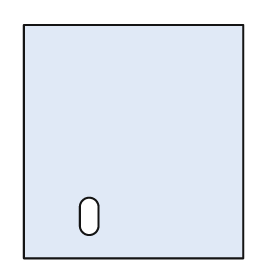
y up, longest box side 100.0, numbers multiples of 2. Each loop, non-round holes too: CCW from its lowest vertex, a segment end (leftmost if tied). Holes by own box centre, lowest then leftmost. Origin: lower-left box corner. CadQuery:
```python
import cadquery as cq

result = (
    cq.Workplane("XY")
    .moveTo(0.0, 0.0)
    .lineTo(94.0, 0.0)
    .lineTo(94.0, 100.0)
    .lineTo(0.0, 100.0)
    .close()
    .moveTo(24.0, 14.0)
    .threePointArc((28.0, 10.0), (32.0, 14.0))
    .lineTo(32.0, 22.0)
    .threePointArc((28.0, 26.0), (24.0, 22.0))
    .close()
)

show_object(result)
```